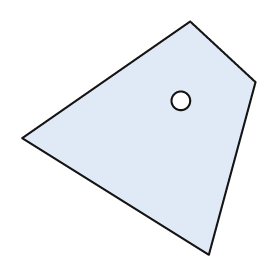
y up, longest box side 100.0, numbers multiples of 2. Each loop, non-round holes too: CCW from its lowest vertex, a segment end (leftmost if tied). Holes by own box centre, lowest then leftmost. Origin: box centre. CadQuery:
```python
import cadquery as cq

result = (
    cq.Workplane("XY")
    .moveTo(30.0, -50.0)
    .lineTo(50.0, 24.0)
    .lineTo(22.0, 50.0)
    .lineTo(-50.0, 0.0)
    .close()
    .moveTo(18.0, 16.0)
    .circle(4.0)
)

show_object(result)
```